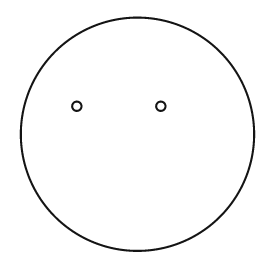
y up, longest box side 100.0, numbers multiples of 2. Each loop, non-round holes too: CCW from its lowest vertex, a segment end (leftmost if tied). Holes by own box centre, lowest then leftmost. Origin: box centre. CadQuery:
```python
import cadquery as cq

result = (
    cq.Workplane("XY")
    .moveTo(0.0, 0.0)
    .circle(50.0)
    .moveTo(-26.0, 12.0)
    .circle(2.0)
    .moveTo(10.0, 12.0)
    .circle(2.0)
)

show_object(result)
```